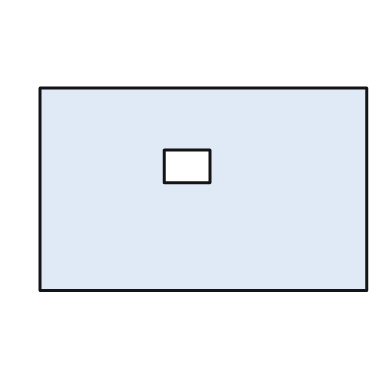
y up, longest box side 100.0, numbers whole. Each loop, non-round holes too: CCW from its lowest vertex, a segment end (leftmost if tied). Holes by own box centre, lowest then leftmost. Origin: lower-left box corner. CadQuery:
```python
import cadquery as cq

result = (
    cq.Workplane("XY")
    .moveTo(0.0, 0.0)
    .lineTo(100.0, 0.0)
    .lineTo(100.0, 62.0)
    .lineTo(0.0, 62.0)
    .close()
    .moveTo(38.0, 33.0)
    .lineTo(52.0, 33.0)
    .lineTo(52.0, 43.0)
    .lineTo(38.0, 43.0)
    .close()
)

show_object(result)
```